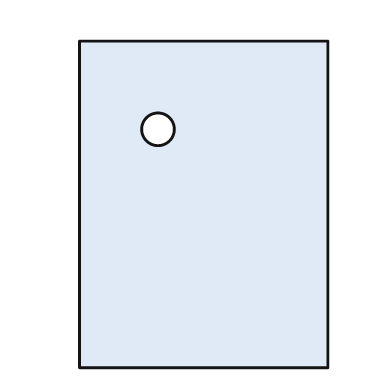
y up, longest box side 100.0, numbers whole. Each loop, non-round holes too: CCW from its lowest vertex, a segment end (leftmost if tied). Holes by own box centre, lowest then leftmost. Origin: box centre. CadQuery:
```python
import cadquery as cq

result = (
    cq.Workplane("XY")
    .moveTo(-38.0, -50.0)
    .lineTo(38.0, -50.0)
    .lineTo(38.0, 50.0)
    .lineTo(-38.0, 50.0)
    .close()
    .moveTo(-14.0, 23.0)
    .circle(5.0)
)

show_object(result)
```